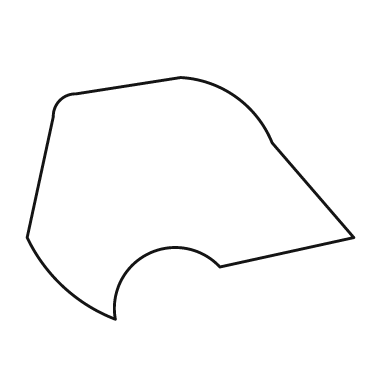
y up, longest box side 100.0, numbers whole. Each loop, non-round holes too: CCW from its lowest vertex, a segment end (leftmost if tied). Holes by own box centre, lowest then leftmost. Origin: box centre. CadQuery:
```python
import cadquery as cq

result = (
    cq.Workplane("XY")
    .moveTo(-23.0, -37.0)
    .threePointArc((-13.0, -17.0), (9.0, -21.0))
    .lineTo(50.0, -12.0)
    .lineTo(25.0, 17.0)
    .threePointArc((14.0, 31.0), (-3.0, 37.0))
    .lineTo(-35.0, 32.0)
    .threePointArc((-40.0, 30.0), (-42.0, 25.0))
    .lineTo(-50.0, -12.0)
    .threePointArc((-39.0, -27.0), (-23.0, -37.0))
    .close()
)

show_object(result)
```